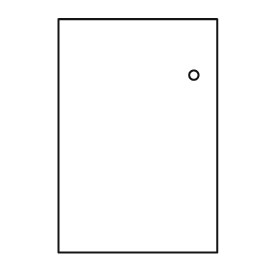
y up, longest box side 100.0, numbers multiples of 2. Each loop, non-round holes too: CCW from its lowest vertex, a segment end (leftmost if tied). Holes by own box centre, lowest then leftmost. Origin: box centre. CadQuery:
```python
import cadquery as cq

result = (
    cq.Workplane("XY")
    .moveTo(-34.0, -50.0)
    .lineTo(34.0, -50.0)
    .lineTo(34.0, 50.0)
    .lineTo(-34.0, 50.0)
    .close()
    .moveTo(24.0, 26.0)
    .circle(2.0)
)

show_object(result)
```